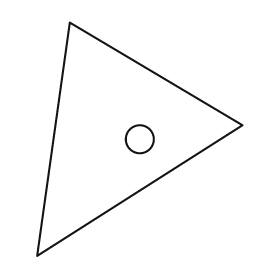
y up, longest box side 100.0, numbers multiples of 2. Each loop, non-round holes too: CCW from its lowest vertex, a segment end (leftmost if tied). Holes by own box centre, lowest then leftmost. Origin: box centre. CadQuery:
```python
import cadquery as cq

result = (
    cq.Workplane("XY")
    .moveTo(-44.0, -50.0)
    .lineTo(44.0, 6.0)
    .lineTo(-30.0, 50.0)
    .close()
    .moveTo(0.0, 0.0)
    .circle(6.0)
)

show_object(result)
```